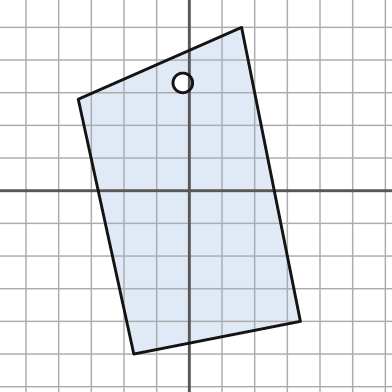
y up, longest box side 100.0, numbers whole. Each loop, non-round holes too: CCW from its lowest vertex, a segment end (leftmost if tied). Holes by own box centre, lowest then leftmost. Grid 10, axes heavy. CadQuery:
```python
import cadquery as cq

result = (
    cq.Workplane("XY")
    .moveTo(-17.0, -50.0)
    .lineTo(34.0, -40.0)
    .lineTo(16.0, 50.0)
    .lineTo(-34.0, 28.0)
    .close()
    .moveTo(-2.0, 33.0)
    .circle(3.0)
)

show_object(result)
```